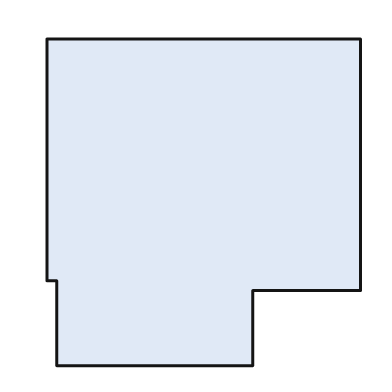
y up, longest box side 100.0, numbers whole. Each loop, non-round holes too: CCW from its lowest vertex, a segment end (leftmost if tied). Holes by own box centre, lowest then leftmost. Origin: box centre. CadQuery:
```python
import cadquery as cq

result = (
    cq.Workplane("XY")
    .moveTo(-45.0, -50.0)
    .lineTo(15.0, -50.0)
    .lineTo(15.0, -27.0)
    .lineTo(48.0, -27.0)
    .lineTo(48.0, 50.0)
    .lineTo(-48.0, 50.0)
    .lineTo(-48.0, -24.0)
    .lineTo(-45.0, -24.0)
    .close()
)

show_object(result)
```